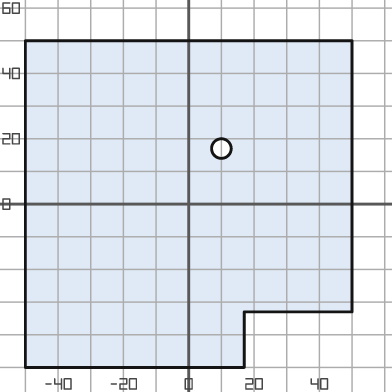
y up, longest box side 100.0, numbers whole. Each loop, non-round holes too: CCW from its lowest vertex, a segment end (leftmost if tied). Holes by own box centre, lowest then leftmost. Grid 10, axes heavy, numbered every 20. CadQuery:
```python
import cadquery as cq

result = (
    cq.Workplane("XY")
    .moveTo(-50.0, -50.0)
    .lineTo(17.0, -50.0)
    .lineTo(17.0, -33.0)
    .lineTo(50.0, -33.0)
    .lineTo(50.0, 50.0)
    .lineTo(-50.0, 50.0)
    .close()
    .moveTo(10.0, 17.0)
    .circle(3.0)
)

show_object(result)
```